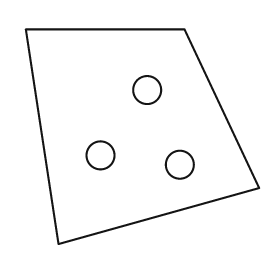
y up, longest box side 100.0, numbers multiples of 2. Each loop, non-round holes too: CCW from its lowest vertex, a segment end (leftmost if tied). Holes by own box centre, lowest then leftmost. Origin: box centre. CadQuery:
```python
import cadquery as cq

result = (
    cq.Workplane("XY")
    .moveTo(-36.0, -46.0)
    .lineTo(50.0, -22.0)
    .lineTo(18.0, 46.0)
    .lineTo(-50.0, 46.0)
    .close()
    .moveTo(16.0, -12.0)
    .circle(6.0)
    .moveTo(-18.0, -8.0)
    .circle(6.0)
    .moveTo(2.0, 20.0)
    .circle(6.0)
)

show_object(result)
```